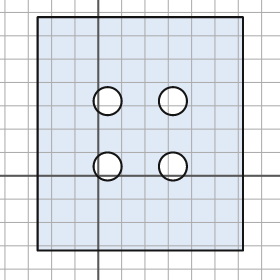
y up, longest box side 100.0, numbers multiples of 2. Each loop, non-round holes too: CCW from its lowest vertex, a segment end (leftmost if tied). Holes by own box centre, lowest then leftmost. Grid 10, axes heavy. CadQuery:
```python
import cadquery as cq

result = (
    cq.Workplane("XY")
    .moveTo(-26.0, -32.0)
    .lineTo(62.0, -32.0)
    .lineTo(62.0, 68.0)
    .lineTo(-26.0, 68.0)
    .close()
    .moveTo(4.0, 4.0)
    .circle(6.0)
    .moveTo(32.0, 4.0)
    .circle(6.0)
    .moveTo(4.0, 32.0)
    .circle(6.0)
    .moveTo(32.0, 32.0)
    .circle(6.0)
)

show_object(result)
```